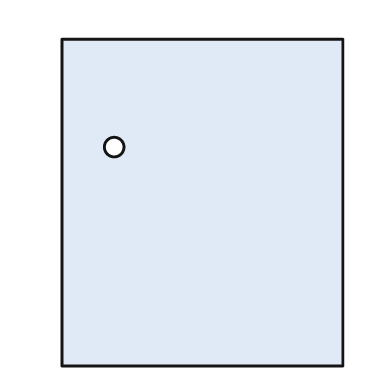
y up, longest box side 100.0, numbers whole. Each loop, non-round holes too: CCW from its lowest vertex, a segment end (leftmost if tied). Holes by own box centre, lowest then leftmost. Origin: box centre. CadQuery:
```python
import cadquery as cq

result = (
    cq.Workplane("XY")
    .moveTo(-43.0, -50.0)
    .lineTo(43.0, -50.0)
    .lineTo(43.0, 50.0)
    .lineTo(-43.0, 50.0)
    .close()
    .moveTo(-27.0, 17.0)
    .circle(3.0)
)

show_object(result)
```